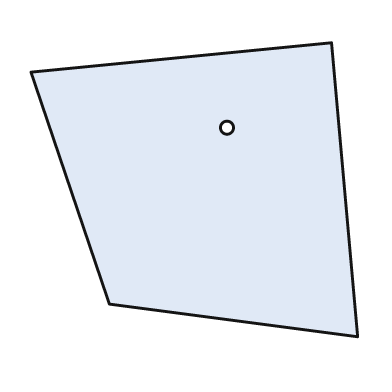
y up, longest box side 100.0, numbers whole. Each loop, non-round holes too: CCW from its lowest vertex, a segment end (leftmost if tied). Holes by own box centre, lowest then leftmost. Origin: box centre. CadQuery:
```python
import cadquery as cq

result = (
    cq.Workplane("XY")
    .moveTo(50.0, -45.0)
    .lineTo(42.0, 45.0)
    .lineTo(-50.0, 36.0)
    .lineTo(-26.0, -35.0)
    .close()
    .moveTo(10.0, 19.0)
    .circle(2.0)
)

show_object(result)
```